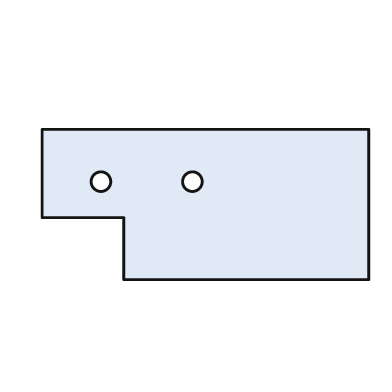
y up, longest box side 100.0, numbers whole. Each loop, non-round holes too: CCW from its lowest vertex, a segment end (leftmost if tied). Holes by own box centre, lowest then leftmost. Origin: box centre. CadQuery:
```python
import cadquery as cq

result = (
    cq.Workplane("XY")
    .moveTo(-25.0, -23.0)
    .lineTo(50.0, -23.0)
    .lineTo(50.0, 23.0)
    .lineTo(-50.0, 23.0)
    .lineTo(-50.0, -4.0)
    .lineTo(-25.0, -4.0)
    .close()
    .moveTo(-32.0, 7.0)
    .circle(3.0)
    .moveTo(-4.0, 7.0)
    .circle(3.0)
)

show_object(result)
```